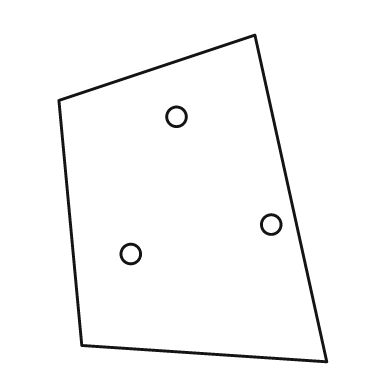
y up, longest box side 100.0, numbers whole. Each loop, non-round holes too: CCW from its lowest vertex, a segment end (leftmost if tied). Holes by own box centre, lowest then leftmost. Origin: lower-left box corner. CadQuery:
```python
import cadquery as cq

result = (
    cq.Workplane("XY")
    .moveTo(82.0, 0.0)
    .lineTo(60.0, 100.0)
    .lineTo(0.0, 80.0)
    .lineTo(7.0, 5.0)
    .close()
    .moveTo(22.0, 33.0)
    .circle(3.0)
    .moveTo(65.0, 42.0)
    .circle(3.0)
    .moveTo(36.0, 75.0)
    .circle(3.0)
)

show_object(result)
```